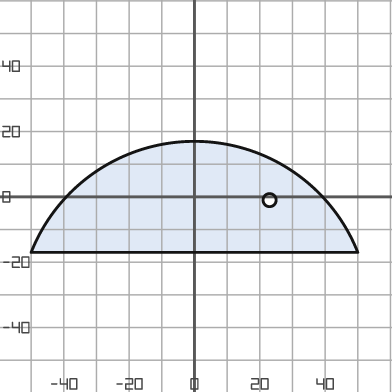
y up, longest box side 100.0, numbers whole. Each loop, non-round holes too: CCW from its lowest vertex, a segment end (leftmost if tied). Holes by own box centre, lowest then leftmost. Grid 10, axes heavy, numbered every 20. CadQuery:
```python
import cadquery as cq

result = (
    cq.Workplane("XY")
    .moveTo(-50.0, -17.0)
    .lineTo(50.0, -17.0)
    .threePointArc((0.0, 17.0), (-50.0, -17.0))
    .close()
    .moveTo(23.0, -1.0)
    .circle(2.0)
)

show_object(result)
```